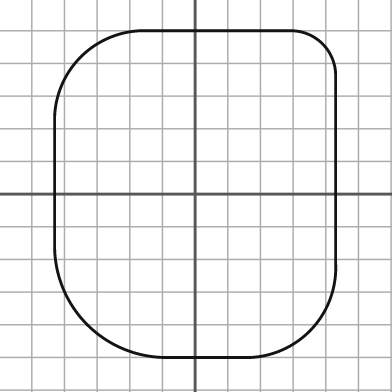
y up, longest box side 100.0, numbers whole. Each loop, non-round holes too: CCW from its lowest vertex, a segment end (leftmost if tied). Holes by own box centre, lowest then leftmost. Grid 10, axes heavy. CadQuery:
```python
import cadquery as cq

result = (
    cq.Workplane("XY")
    .moveTo(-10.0, -50.0)
    .lineTo(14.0, -50.0)
    .threePointArc((35.0, -42.0), (43.0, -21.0))
    .lineTo(43.0, 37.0)
    .threePointArc((39.0, 46.0), (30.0, 50.0))
    .lineTo(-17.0, 50.0)
    .threePointArc((-35.0, 42.0), (-43.0, 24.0))
    .lineTo(-43.0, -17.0)
    .threePointArc((-33.0, -40.0), (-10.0, -50.0))
    .close()
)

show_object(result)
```